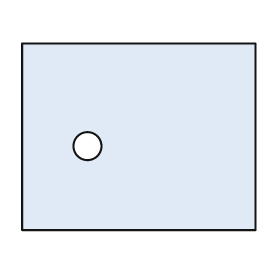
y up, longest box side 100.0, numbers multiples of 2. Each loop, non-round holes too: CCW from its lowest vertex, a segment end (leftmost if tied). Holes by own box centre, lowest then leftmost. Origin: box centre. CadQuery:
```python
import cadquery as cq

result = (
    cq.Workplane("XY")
    .moveTo(-50.0, -40.0)
    .lineTo(50.0, -40.0)
    .lineTo(50.0, 40.0)
    .lineTo(-50.0, 40.0)
    .close()
    .moveTo(-22.0, -4.0)
    .circle(6.0)
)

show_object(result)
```